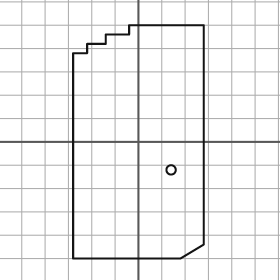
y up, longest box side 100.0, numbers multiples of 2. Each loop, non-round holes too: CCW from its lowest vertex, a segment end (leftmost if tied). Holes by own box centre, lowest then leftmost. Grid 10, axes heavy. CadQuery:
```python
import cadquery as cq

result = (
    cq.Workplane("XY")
    .moveTo(-28.0, -50.0)
    .lineTo(18.0, -50.0)
    .lineTo(28.0, -44.0)
    .lineTo(28.0, 50.0)
    .lineTo(-4.0, 50.0)
    .lineTo(-4.0, 46.0)
    .lineTo(-14.0, 46.0)
    .lineTo(-14.0, 42.0)
    .lineTo(-22.0, 42.0)
    .lineTo(-22.0, 38.0)
    .lineTo(-28.0, 38.0)
    .close()
    .moveTo(14.0, -12.0)
    .circle(2.0)
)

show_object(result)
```